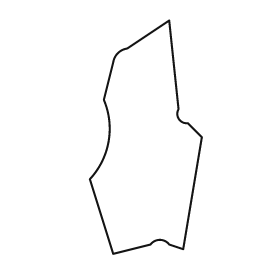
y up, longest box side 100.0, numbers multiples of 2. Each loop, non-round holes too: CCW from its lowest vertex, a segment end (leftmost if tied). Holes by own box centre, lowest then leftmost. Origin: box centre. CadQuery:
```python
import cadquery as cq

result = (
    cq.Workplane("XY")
    .moveTo(-14.0, -50.0)
    .lineTo(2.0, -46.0)
    .threePointArc((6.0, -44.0), (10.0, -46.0))
    .lineTo(16.0, -48.0)
    .lineTo(24.0, 0.0)
    .lineTo(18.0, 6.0)
    .threePointArc((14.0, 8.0), (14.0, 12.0))
    .lineTo(10.0, 50.0)
    .lineTo(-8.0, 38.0)
    .threePointArc((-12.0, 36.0), (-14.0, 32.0))
    .lineTo(-18.0, 16.0)
    .threePointArc((-16.0, -2.0), (-24.0, -18.0))
    .close()
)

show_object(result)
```